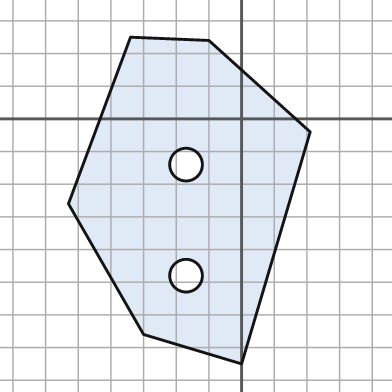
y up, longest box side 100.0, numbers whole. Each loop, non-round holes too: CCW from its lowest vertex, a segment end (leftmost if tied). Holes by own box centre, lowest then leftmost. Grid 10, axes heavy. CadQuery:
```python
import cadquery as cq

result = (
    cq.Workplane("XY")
    .moveTo(0.0, -75.0)
    .lineTo(21.0, -4.0)
    .lineTo(-10.0, 24.0)
    .lineTo(-34.0, 25.0)
    .lineTo(-53.0, -26.0)
    .lineTo(-30.0, -66.0)
    .close()
    .moveTo(-17.0, -48.0)
    .circle(5.0)
    .moveTo(-17.0, -14.0)
    .circle(5.0)
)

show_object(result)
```